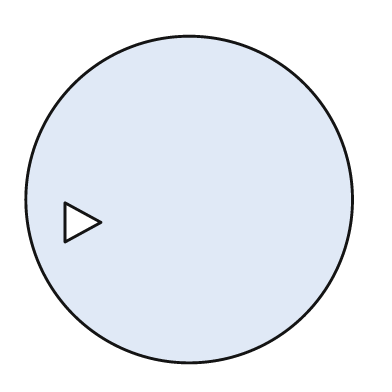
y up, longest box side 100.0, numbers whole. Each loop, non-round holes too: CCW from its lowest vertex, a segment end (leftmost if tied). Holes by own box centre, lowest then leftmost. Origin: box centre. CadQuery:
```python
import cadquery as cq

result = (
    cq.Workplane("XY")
    .moveTo(0.0, 0.0)
    .circle(50.0)
    .moveTo(-38.0, -13.0)
    .lineTo(-27.0, -7.0)
    .lineTo(-38.0, -1.0)
    .close()
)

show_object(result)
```